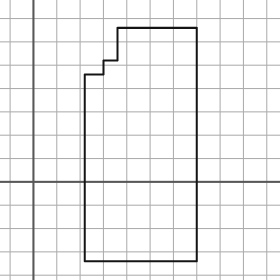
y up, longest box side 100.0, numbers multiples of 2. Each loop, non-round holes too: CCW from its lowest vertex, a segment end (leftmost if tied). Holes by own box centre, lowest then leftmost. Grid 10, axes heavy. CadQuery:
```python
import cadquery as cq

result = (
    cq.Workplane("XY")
    .moveTo(22.0, -34.0)
    .lineTo(70.0, -34.0)
    .lineTo(70.0, 66.0)
    .lineTo(36.0, 66.0)
    .lineTo(36.0, 52.0)
    .lineTo(30.0, 52.0)
    .lineTo(30.0, 46.0)
    .lineTo(22.0, 46.0)
    .close()
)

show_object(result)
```